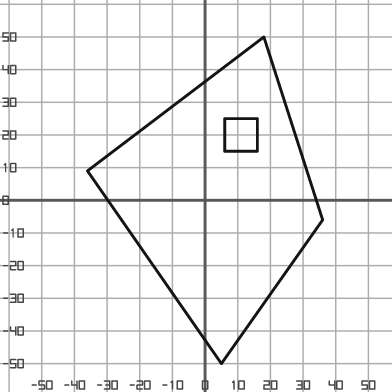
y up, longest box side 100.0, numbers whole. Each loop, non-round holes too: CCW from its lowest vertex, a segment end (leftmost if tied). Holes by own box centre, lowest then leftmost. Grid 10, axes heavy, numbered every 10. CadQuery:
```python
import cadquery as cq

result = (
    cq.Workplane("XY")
    .moveTo(5.0, -50.0)
    .lineTo(36.0, -6.0)
    .lineTo(18.0, 50.0)
    .lineTo(-36.0, 9.0)
    .close()
    .moveTo(6.0, 15.0)
    .lineTo(16.0, 15.0)
    .lineTo(16.0, 25.0)
    .lineTo(6.0, 25.0)
    .close()
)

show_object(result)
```